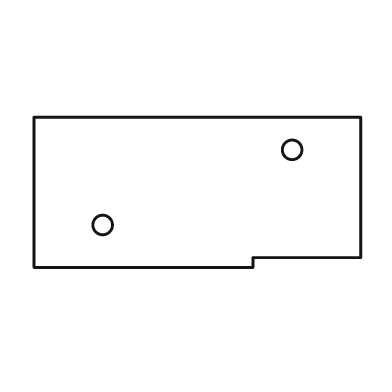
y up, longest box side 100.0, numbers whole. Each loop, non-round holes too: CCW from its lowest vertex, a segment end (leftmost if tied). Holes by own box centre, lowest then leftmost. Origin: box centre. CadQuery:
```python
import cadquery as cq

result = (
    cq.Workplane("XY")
    .moveTo(-50.0, -23.0)
    .lineTo(17.0, -23.0)
    .lineTo(17.0, -20.0)
    .lineTo(50.0, -20.0)
    .lineTo(50.0, 23.0)
    .lineTo(-50.0, 23.0)
    .close()
    .moveTo(-29.0, -10.0)
    .circle(3.0)
    .moveTo(29.0, 13.0)
    .circle(3.0)
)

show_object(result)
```